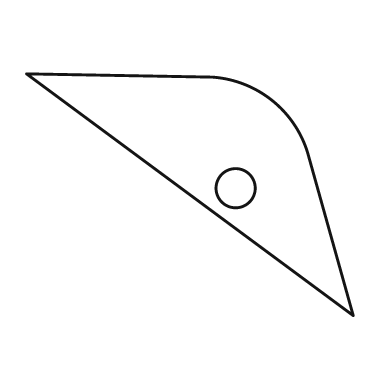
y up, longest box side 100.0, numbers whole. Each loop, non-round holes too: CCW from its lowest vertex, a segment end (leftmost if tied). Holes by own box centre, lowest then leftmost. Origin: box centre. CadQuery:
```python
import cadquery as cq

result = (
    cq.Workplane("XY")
    .moveTo(50.0, -37.0)
    .lineTo(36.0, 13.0)
    .threePointArc((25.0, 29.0), (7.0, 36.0))
    .lineTo(-50.0, 37.0)
    .close()
    .moveTo(14.0, 2.0)
    .circle(6.0)
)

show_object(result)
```